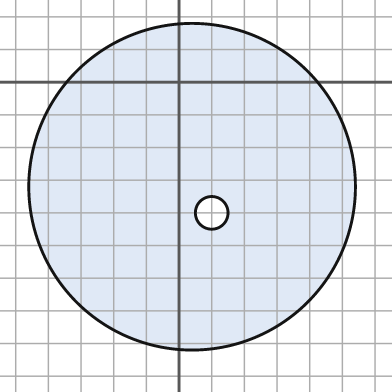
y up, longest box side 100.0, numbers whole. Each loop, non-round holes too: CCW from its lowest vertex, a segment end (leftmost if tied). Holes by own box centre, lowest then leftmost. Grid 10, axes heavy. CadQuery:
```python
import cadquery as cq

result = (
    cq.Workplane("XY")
    .moveTo(4.0, -32.0)
    .circle(50.0)
    .moveTo(10.0, -40.0)
    .circle(5.0)
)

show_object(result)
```